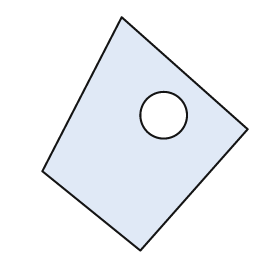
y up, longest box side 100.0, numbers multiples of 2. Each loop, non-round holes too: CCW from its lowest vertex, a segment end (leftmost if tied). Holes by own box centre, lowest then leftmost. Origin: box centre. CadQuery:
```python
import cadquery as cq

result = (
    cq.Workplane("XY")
    .moveTo(-2.0, -50.0)
    .lineTo(44.0, 2.0)
    .lineTo(-10.0, 50.0)
    .lineTo(-44.0, -16.0)
    .close()
    .moveTo(8.0, 8.0)
    .circle(10.0)
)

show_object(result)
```